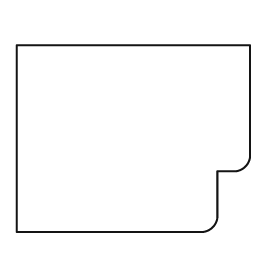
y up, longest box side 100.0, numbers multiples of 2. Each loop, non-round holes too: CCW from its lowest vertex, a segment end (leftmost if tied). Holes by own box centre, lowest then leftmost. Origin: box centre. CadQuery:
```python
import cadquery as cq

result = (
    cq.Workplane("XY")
    .moveTo(-50.0, -40.0)
    .lineTo(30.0, -40.0)
    .threePointArc((34.0, -38.0), (36.0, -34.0))
    .lineTo(36.0, -14.0)
    .lineTo(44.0, -14.0)
    .threePointArc((48.0, -12.0), (50.0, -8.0))
    .lineTo(50.0, 40.0)
    .lineTo(-50.0, 40.0)
    .close()
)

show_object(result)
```